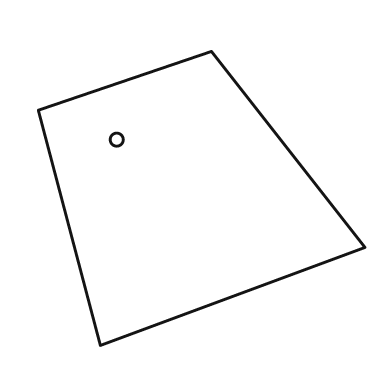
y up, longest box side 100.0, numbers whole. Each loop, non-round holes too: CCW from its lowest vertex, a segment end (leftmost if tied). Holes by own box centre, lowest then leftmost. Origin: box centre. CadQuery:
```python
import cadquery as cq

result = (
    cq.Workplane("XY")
    .moveTo(-31.0, -45.0)
    .lineTo(50.0, -15.0)
    .lineTo(3.0, 45.0)
    .lineTo(-50.0, 27.0)
    .close()
    .moveTo(-26.0, 18.0)
    .circle(2.0)
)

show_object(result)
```